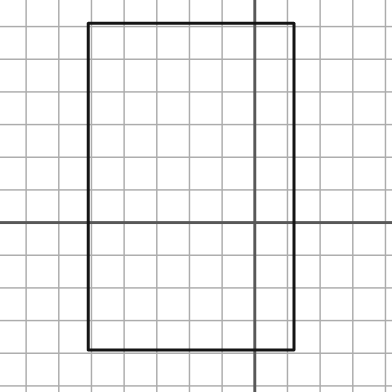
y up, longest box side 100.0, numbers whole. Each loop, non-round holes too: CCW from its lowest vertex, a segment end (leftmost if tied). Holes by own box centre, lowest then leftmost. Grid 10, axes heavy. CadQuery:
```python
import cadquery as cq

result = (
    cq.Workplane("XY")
    .moveTo(-51.0, -39.0)
    .lineTo(12.0, -39.0)
    .lineTo(12.0, 61.0)
    .lineTo(-51.0, 61.0)
    .close()
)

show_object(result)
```